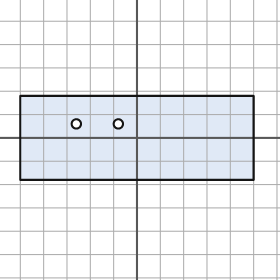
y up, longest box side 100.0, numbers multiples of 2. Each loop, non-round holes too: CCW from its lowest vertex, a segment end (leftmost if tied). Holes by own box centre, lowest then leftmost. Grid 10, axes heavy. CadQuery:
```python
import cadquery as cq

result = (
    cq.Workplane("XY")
    .moveTo(-50.0, -18.0)
    .lineTo(50.0, -18.0)
    .lineTo(50.0, 18.0)
    .lineTo(-50.0, 18.0)
    .close()
    .moveTo(-26.0, 6.0)
    .circle(2.0)
    .moveTo(-8.0, 6.0)
    .circle(2.0)
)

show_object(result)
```